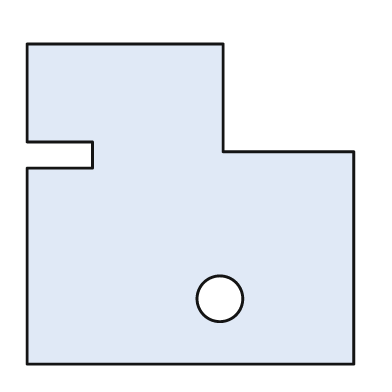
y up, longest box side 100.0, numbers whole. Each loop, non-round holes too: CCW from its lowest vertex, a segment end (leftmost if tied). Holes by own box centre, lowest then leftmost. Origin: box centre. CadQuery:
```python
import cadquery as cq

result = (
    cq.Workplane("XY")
    .moveTo(-50.0, -49.0)
    .lineTo(50.0, -49.0)
    .lineTo(50.0, 16.0)
    .lineTo(10.0, 16.0)
    .lineTo(10.0, 49.0)
    .lineTo(-50.0, 49.0)
    .lineTo(-50.0, 19.0)
    .lineTo(-30.0, 19.0)
    .lineTo(-30.0, 11.0)
    .lineTo(-50.0, 11.0)
    .close()
    .moveTo(9.0, -29.0)
    .circle(7.0)
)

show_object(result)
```